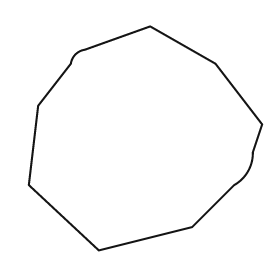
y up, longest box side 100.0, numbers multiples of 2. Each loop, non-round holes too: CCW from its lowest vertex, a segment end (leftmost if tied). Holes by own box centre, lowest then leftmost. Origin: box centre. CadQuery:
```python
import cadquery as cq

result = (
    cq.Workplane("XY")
    .moveTo(-20.0, -48.0)
    .lineTo(20.0, -38.0)
    .lineTo(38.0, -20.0)
    .threePointArc((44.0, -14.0), (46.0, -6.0))
    .lineTo(50.0, 6.0)
    .lineTo(30.0, 32.0)
    .lineTo(2.0, 48.0)
    .lineTo(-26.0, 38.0)
    .threePointArc((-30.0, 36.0), (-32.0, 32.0))
    .lineTo(-46.0, 14.0)
    .lineTo(-50.0, -20.0)
    .close()
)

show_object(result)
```